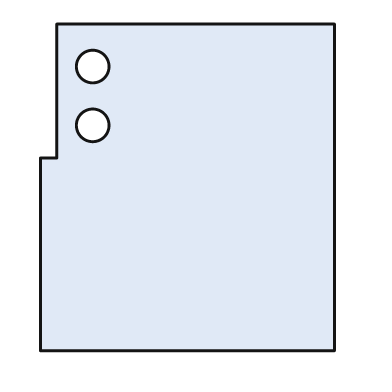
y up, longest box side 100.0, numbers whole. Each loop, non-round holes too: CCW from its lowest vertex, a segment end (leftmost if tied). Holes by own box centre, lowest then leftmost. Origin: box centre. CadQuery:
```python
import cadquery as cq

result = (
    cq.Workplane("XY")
    .moveTo(-45.0, -50.0)
    .lineTo(45.0, -50.0)
    .lineTo(45.0, 50.0)
    .lineTo(-40.0, 50.0)
    .lineTo(-40.0, 9.0)
    .lineTo(-45.0, 9.0)
    .close()
    .moveTo(-29.0, 19.0)
    .circle(5.0)
    .moveTo(-29.0, 37.0)
    .circle(5.0)
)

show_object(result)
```